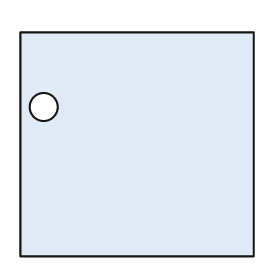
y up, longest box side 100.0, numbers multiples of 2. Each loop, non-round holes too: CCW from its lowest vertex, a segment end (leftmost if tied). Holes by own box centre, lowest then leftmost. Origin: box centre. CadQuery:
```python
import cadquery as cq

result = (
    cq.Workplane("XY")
    .moveTo(-50.0, -48.0)
    .lineTo(50.0, -48.0)
    .lineTo(50.0, 48.0)
    .lineTo(-50.0, 48.0)
    .close()
    .moveTo(-40.0, 16.0)
    .circle(6.0)
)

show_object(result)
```